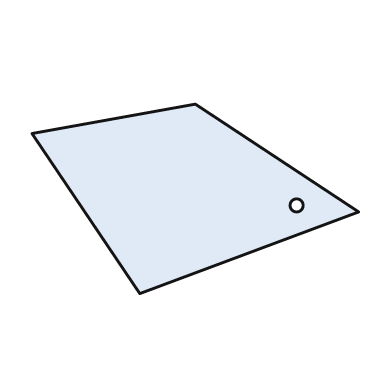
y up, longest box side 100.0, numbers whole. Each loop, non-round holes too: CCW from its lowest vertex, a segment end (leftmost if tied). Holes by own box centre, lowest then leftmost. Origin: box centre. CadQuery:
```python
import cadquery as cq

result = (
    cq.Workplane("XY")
    .moveTo(-17.0, -29.0)
    .lineTo(50.0, -4.0)
    .lineTo(0.0, 29.0)
    .lineTo(-50.0, 20.0)
    .close()
    .moveTo(31.0, -2.0)
    .circle(2.0)
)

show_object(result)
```